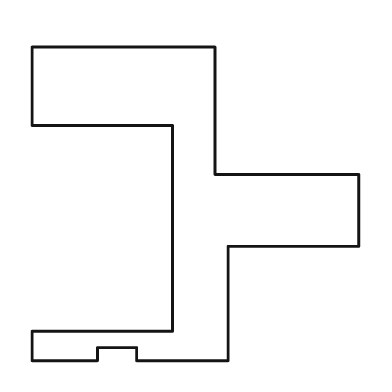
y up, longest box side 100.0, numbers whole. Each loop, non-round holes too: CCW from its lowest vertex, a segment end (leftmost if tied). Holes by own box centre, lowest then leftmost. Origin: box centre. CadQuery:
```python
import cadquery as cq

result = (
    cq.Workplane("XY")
    .moveTo(-50.0, -48.0)
    .lineTo(-30.0, -48.0)
    .lineTo(-30.0, -44.0)
    .lineTo(-18.0, -44.0)
    .lineTo(-18.0, -48.0)
    .lineTo(10.0, -48.0)
    .lineTo(10.0, -13.0)
    .lineTo(50.0, -13.0)
    .lineTo(50.0, 9.0)
    .lineTo(6.0, 9.0)
    .lineTo(6.0, 48.0)
    .lineTo(-50.0, 48.0)
    .lineTo(-50.0, 24.0)
    .lineTo(-7.0, 24.0)
    .lineTo(-7.0, -39.0)
    .lineTo(-50.0, -39.0)
    .close()
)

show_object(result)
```